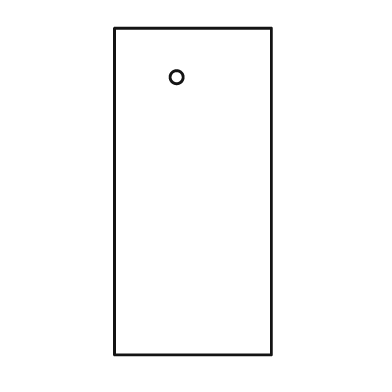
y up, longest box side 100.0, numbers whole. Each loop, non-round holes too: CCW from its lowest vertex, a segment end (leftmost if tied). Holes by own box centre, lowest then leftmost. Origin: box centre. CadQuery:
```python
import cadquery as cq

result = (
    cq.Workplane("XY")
    .moveTo(-24.0, -50.0)
    .lineTo(24.0, -50.0)
    .lineTo(24.0, 50.0)
    .lineTo(-24.0, 50.0)
    .close()
    .moveTo(-5.0, 35.0)
    .circle(2.0)
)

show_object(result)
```